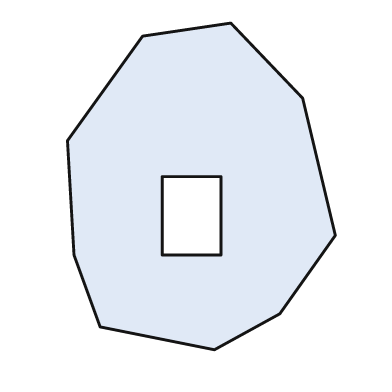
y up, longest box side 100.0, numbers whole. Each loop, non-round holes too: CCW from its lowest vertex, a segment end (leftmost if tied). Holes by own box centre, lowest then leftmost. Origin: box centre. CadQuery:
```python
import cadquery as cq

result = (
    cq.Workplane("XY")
    .moveTo(4.0, -50.0)
    .lineTo(24.0, -39.0)
    .lineTo(41.0, -15.0)
    .lineTo(31.0, 27.0)
    .lineTo(9.0, 50.0)
    .lineTo(-18.0, 46.0)
    .lineTo(-41.0, 14.0)
    .lineTo(-39.0, -21.0)
    .lineTo(-31.0, -43.0)
    .close()
    .moveTo(-12.0, -21.0)
    .lineTo(6.0, -21.0)
    .lineTo(6.0, 3.0)
    .lineTo(-12.0, 3.0)
    .close()
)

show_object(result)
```